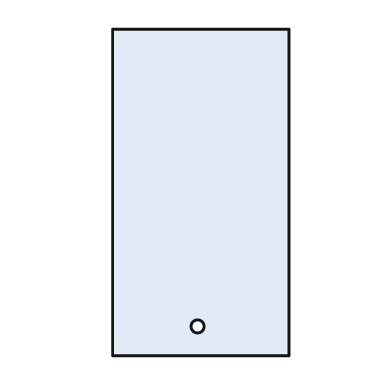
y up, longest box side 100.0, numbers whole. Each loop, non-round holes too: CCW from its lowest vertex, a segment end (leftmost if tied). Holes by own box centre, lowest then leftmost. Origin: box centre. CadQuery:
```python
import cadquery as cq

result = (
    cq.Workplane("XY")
    .moveTo(-27.0, -50.0)
    .lineTo(27.0, -50.0)
    .lineTo(27.0, 50.0)
    .lineTo(-27.0, 50.0)
    .close()
    .moveTo(-1.0, -41.0)
    .circle(2.0)
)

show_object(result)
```